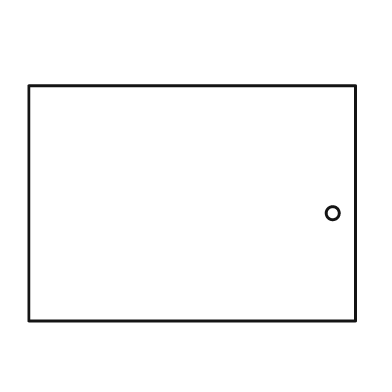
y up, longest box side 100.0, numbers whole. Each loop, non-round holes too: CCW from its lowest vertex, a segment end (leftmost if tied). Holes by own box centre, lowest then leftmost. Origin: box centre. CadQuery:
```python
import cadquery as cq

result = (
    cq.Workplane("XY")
    .moveTo(-50.0, -36.0)
    .lineTo(50.0, -36.0)
    .lineTo(50.0, 36.0)
    .lineTo(-50.0, 36.0)
    .close()
    .moveTo(43.0, -3.0)
    .circle(2.0)
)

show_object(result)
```